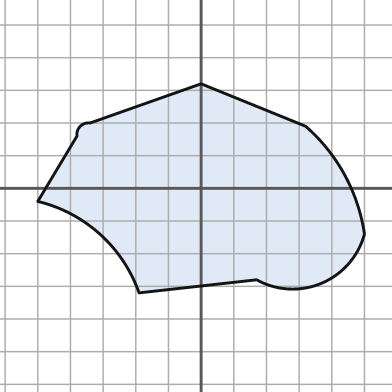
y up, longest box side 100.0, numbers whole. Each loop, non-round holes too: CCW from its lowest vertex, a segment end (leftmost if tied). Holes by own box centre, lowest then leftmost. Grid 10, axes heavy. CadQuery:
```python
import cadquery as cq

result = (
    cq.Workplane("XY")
    .moveTo(-19.0, -32.0)
    .lineTo(17.0, -28.0)
    .threePointArc((37.0, -29.0), (50.0, -14.0))
    .threePointArc((44.0, 4.0), (32.0, 19.0))
    .lineTo(0.0, 32.0)
    .lineTo(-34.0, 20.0)
    .threePointArc((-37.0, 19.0), (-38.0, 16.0))
    .lineTo(-50.0, -4.0)
    .threePointArc((-31.0, -14.0), (-19.0, -32.0))
    .close()
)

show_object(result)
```